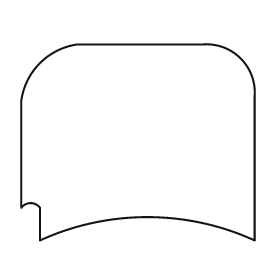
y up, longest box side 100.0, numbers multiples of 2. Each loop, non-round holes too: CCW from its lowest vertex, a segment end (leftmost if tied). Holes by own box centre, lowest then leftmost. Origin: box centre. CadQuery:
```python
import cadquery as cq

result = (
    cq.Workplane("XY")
    .moveTo(-42.0, -42.0)
    .threePointArc((4.0, -32.0), (50.0, -42.0))
    .lineTo(50.0, 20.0)
    .threePointArc((44.0, 36.0), (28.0, 42.0))
    .lineTo(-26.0, 42.0)
    .threePointArc((-42.0, 34.0), (-50.0, 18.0))
    .lineTo(-50.0, -28.0)
    .threePointArc((-46.0, -26.0), (-42.0, -28.0))
    .close()
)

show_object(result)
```